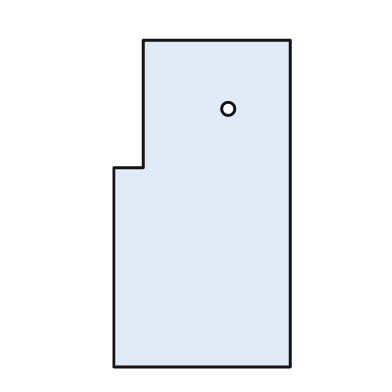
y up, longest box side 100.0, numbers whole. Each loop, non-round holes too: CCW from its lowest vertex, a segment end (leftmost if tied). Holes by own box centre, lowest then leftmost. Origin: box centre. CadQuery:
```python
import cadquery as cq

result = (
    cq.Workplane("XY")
    .moveTo(-27.0, -50.0)
    .lineTo(27.0, -50.0)
    .lineTo(27.0, 50.0)
    .lineTo(-18.0, 50.0)
    .lineTo(-18.0, 11.0)
    .lineTo(-27.0, 11.0)
    .close()
    .moveTo(8.0, 29.0)
    .circle(2.0)
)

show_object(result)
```